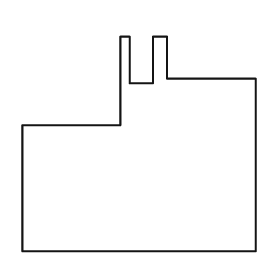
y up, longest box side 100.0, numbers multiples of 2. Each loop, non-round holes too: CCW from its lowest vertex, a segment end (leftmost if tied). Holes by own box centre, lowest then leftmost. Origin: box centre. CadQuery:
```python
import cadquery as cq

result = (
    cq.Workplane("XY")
    .moveTo(-50.0, -46.0)
    .lineTo(50.0, -46.0)
    .lineTo(50.0, 28.0)
    .lineTo(12.0, 28.0)
    .lineTo(12.0, 46.0)
    .lineTo(6.0, 46.0)
    .lineTo(6.0, 26.0)
    .lineTo(-4.0, 26.0)
    .lineTo(-4.0, 46.0)
    .lineTo(-8.0, 46.0)
    .lineTo(-8.0, 8.0)
    .lineTo(-50.0, 8.0)
    .close()
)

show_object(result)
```